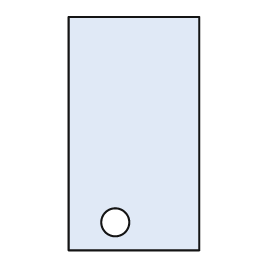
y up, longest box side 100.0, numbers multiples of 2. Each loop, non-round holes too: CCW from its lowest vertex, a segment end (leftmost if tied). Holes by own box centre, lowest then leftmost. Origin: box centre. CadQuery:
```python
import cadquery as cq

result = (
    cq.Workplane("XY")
    .moveTo(-28.0, -50.0)
    .lineTo(28.0, -50.0)
    .lineTo(28.0, 50.0)
    .lineTo(-28.0, 50.0)
    .close()
    .moveTo(-8.0, -38.0)
    .circle(6.0)
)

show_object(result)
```